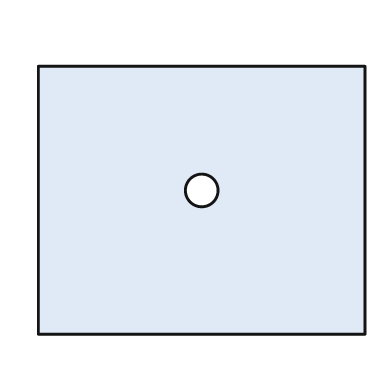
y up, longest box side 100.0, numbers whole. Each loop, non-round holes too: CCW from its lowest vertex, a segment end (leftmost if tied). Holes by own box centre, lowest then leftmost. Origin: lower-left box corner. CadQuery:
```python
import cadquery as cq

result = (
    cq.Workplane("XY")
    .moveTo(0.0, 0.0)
    .lineTo(100.0, 0.0)
    .lineTo(100.0, 82.0)
    .lineTo(0.0, 82.0)
    .close()
    .moveTo(50.0, 44.0)
    .circle(5.0)
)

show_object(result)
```